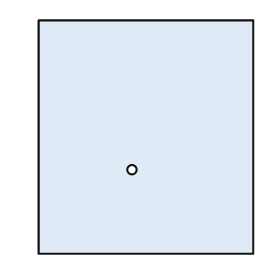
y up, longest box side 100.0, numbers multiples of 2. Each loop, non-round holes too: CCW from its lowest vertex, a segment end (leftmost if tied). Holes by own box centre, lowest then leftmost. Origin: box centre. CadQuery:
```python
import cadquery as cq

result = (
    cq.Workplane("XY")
    .moveTo(-46.0, -50.0)
    .lineTo(46.0, -50.0)
    .lineTo(46.0, 50.0)
    .lineTo(-46.0, 50.0)
    .close()
    .moveTo(-6.0, -14.0)
    .circle(2.0)
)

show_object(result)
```